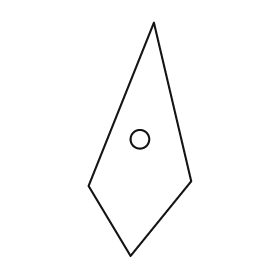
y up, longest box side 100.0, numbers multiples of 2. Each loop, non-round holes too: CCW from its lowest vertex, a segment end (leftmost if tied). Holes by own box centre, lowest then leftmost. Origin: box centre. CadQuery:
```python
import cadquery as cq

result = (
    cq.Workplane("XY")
    .moveTo(-4.0, -50.0)
    .lineTo(22.0, -18.0)
    .lineTo(6.0, 50.0)
    .lineTo(-22.0, -20.0)
    .close()
    .moveTo(0.0, 0.0)
    .circle(4.0)
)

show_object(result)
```